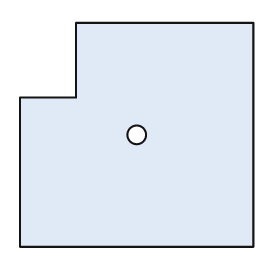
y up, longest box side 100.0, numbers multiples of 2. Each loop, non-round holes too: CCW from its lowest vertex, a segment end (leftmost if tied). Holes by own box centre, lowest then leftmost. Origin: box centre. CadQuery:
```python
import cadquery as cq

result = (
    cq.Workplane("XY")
    .moveTo(-50.0, -48.0)
    .lineTo(50.0, -48.0)
    .lineTo(50.0, 48.0)
    .lineTo(-26.0, 48.0)
    .lineTo(-26.0, 16.0)
    .lineTo(-50.0, 16.0)
    .close()
    .moveTo(0.0, 0.0)
    .circle(4.0)
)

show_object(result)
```